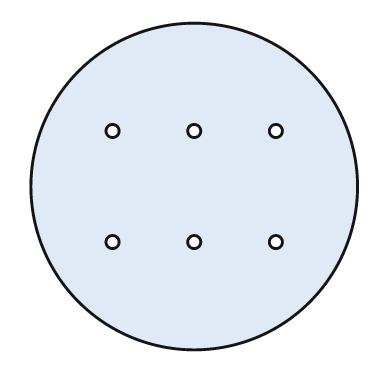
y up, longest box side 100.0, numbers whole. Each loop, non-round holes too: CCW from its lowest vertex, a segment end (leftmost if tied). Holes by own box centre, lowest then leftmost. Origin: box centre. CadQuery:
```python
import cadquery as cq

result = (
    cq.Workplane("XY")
    .moveTo(0.0, 0.0)
    .circle(50.0)
    .moveTo(-25.0, -17.0)
    .circle(2.0)
    .moveTo(0.0, -17.0)
    .circle(2.0)
    .moveTo(25.0, -17.0)
    .circle(2.0)
    .moveTo(-25.0, 17.0)
    .circle(2.0)
    .moveTo(0.0, 17.0)
    .circle(2.0)
    .moveTo(25.0, 17.0)
    .circle(2.0)
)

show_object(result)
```